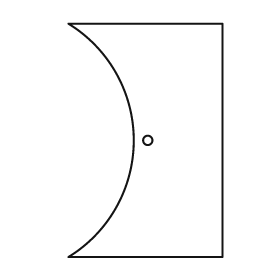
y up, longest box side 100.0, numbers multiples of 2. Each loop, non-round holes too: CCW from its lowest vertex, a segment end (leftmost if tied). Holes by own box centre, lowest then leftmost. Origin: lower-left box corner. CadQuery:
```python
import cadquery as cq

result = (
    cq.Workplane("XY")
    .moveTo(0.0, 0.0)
    .lineTo(66.0, 0.0)
    .lineTo(66.0, 100.0)
    .lineTo(0.0, 100.0)
    .threePointArc((28.0, 50.0), (0.0, 0.0))
    .close()
    .moveTo(34.0, 50.0)
    .circle(2.0)
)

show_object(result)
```